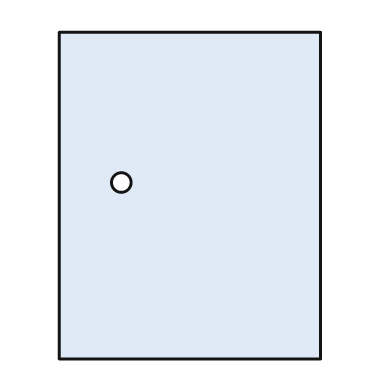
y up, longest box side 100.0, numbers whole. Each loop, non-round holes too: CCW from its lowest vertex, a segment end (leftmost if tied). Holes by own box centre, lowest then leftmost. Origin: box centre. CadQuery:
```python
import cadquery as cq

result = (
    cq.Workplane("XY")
    .moveTo(-40.0, -50.0)
    .lineTo(40.0, -50.0)
    .lineTo(40.0, 50.0)
    .lineTo(-40.0, 50.0)
    .close()
    .moveTo(-21.0, 4.0)
    .circle(3.0)
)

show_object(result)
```